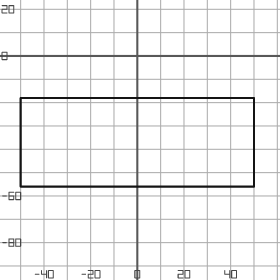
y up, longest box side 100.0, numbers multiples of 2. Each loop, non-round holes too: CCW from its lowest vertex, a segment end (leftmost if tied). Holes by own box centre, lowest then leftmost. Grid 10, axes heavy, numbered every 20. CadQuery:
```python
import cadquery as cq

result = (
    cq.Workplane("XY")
    .moveTo(-50.0, -56.0)
    .lineTo(50.0, -56.0)
    .lineTo(50.0, -18.0)
    .lineTo(-50.0, -18.0)
    .close()
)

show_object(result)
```